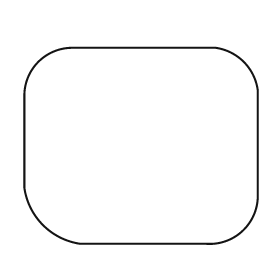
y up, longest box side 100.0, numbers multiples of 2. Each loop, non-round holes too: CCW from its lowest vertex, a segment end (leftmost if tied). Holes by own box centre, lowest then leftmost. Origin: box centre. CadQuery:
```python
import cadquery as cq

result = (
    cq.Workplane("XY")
    .moveTo(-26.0, -42.0)
    .lineTo(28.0, -42.0)
    .threePointArc((44.0, -36.0), (50.0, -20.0))
    .lineTo(50.0, 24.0)
    .threePointArc((44.0, 36.0), (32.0, 42.0))
    .lineTo(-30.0, 42.0)
    .threePointArc((-44.0, 36.0), (-50.0, 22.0))
    .lineTo(-50.0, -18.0)
    .threePointArc((-42.0, -34.0), (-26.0, -42.0))
    .close()
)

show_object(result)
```